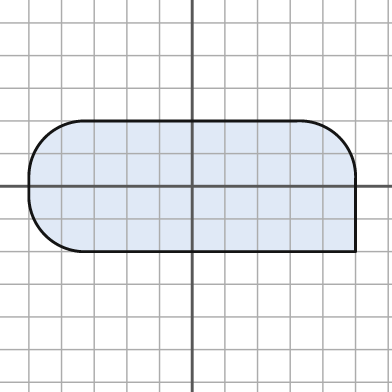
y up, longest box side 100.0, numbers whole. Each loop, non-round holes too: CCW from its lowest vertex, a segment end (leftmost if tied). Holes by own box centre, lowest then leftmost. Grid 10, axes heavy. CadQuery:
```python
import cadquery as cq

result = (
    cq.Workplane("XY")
    .moveTo(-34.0, -20.0)
    .lineTo(50.0, -20.0)
    .lineTo(50.0, 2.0)
    .threePointArc((45.0, 15.0), (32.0, 20.0))
    .lineTo(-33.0, 20.0)
    .threePointArc((-45.0, 15.0), (-50.0, 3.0))
    .lineTo(-50.0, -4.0)
    .threePointArc((-45.0, -15.0), (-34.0, -20.0))
    .close()
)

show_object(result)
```